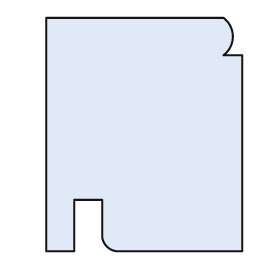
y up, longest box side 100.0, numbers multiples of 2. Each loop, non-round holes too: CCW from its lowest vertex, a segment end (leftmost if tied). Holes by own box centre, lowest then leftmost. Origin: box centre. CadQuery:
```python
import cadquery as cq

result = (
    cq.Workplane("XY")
    .moveTo(-42.0, -50.0)
    .lineTo(-30.0, -50.0)
    .lineTo(-30.0, -28.0)
    .lineTo(-18.0, -28.0)
    .lineTo(-18.0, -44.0)
    .threePointArc((-16.0, -48.0), (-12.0, -50.0))
    .lineTo(42.0, -50.0)
    .lineTo(42.0, 34.0)
    .lineTo(34.0, 34.0)
    .threePointArc((38.0, 42.0), (34.0, 50.0))
    .lineTo(-42.0, 50.0)
    .close()
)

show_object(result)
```